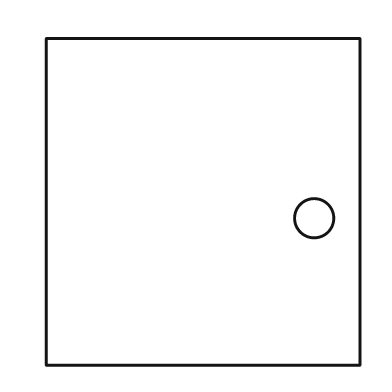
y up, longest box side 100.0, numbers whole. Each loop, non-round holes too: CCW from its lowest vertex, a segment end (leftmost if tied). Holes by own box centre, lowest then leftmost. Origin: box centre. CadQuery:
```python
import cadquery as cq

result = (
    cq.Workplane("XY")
    .moveTo(-48.0, -50.0)
    .lineTo(48.0, -50.0)
    .lineTo(48.0, 50.0)
    .lineTo(-48.0, 50.0)
    .close()
    .moveTo(34.0, -5.0)
    .circle(6.0)
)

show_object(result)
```